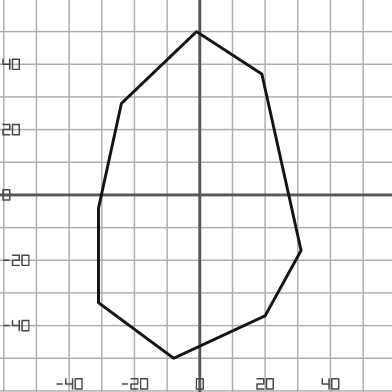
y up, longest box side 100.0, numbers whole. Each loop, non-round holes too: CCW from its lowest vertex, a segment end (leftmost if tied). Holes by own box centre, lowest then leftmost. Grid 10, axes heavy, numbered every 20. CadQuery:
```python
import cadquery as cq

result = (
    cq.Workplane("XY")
    .moveTo(-8.0, -50.0)
    .lineTo(20.0, -37.0)
    .lineTo(31.0, -17.0)
    .lineTo(19.0, 37.0)
    .lineTo(-1.0, 50.0)
    .lineTo(-24.0, 28.0)
    .lineTo(-31.0, -4.0)
    .lineTo(-31.0, -33.0)
    .close()
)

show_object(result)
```